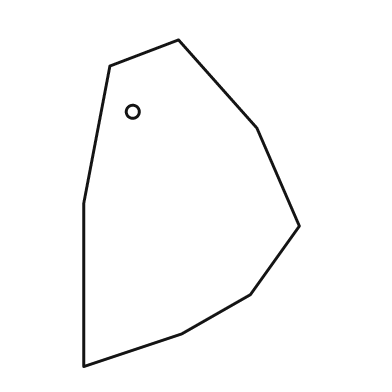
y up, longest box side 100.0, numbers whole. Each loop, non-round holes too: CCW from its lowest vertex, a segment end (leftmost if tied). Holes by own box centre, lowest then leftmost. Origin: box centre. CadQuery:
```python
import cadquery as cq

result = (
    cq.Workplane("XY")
    .moveTo(-33.0, -50.0)
    .lineTo(-3.0, -40.0)
    .lineTo(18.0, -28.0)
    .lineTo(33.0, -7.0)
    .lineTo(20.0, 23.0)
    .lineTo(-4.0, 50.0)
    .lineTo(-25.0, 42.0)
    .lineTo(-33.0, 0.0)
    .close()
    .moveTo(-18.0, 28.0)
    .circle(2.0)
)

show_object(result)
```